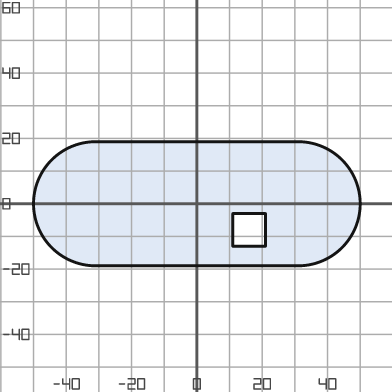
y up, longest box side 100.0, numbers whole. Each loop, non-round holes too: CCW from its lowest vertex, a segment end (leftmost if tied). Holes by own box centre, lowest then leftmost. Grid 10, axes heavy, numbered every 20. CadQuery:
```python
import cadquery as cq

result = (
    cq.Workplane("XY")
    .moveTo(-31.0, -19.0)
    .lineTo(31.0, -19.0)
    .threePointArc((50.0, 0.0), (31.0, 19.0))
    .lineTo(-31.0, 19.0)
    .threePointArc((-50.0, 0.0), (-31.0, -19.0))
    .close()
    .moveTo(11.0, -13.0)
    .lineTo(21.0, -13.0)
    .lineTo(21.0, -3.0)
    .lineTo(11.0, -3.0)
    .close()
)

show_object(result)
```